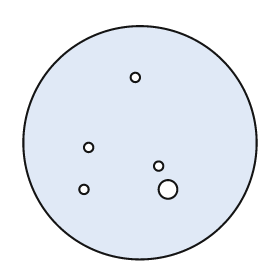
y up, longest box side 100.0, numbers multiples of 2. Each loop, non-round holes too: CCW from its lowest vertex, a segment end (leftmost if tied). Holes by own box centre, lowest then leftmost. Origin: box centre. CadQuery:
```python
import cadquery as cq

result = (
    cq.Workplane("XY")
    .moveTo(0.0, 0.0)
    .circle(50.0)
    .moveTo(-24.0, -20.0)
    .circle(2.0)
    .moveTo(12.0, -20.0)
    .circle(4.0)
    .moveTo(8.0, -10.0)
    .circle(2.0)
    .moveTo(-22.0, -2.0)
    .circle(2.0)
    .moveTo(-2.0, 28.0)
    .circle(2.0)
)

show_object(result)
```